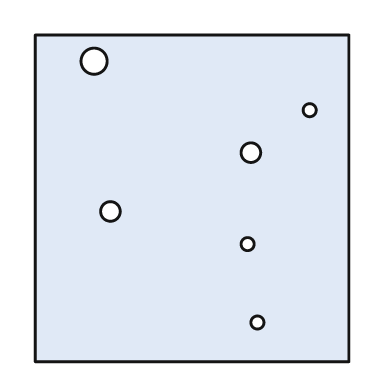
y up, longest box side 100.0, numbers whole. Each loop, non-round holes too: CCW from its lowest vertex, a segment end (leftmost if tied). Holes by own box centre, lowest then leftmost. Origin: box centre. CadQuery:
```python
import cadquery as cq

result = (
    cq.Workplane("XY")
    .moveTo(-48.0, -50.0)
    .lineTo(48.0, -50.0)
    .lineTo(48.0, 50.0)
    .lineTo(-48.0, 50.0)
    .close()
    .moveTo(20.0, -38.0)
    .circle(2.0)
    .moveTo(17.0, -14.0)
    .circle(2.0)
    .moveTo(-25.0, -4.0)
    .circle(3.0)
    .moveTo(18.0, 14.0)
    .circle(3.0)
    .moveTo(36.0, 27.0)
    .circle(2.0)
    .moveTo(-30.0, 42.0)
    .circle(4.0)
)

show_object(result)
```